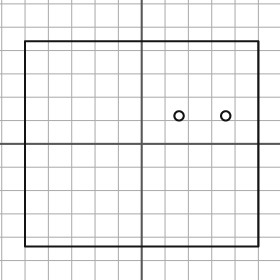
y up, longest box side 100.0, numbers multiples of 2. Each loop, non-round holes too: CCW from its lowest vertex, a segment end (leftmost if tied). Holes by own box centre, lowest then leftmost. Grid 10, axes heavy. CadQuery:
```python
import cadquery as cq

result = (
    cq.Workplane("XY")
    .moveTo(-50.0, -44.0)
    .lineTo(50.0, -44.0)
    .lineTo(50.0, 44.0)
    .lineTo(-50.0, 44.0)
    .close()
    .moveTo(16.0, 12.0)
    .circle(2.0)
    .moveTo(36.0, 12.0)
    .circle(2.0)
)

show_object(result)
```